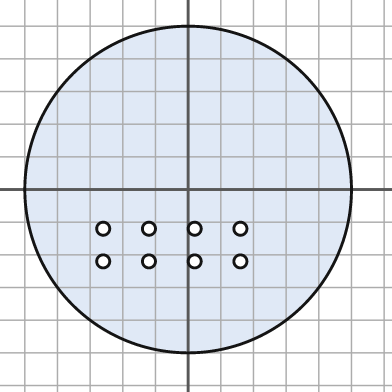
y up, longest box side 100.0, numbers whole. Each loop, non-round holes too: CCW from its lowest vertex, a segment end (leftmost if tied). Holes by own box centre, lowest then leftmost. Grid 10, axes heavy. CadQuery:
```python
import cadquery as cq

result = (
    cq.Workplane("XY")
    .moveTo(0.0, 0.0)
    .circle(50.0)
    .moveTo(-26.0, -22.0)
    .circle(2.0)
    .moveTo(-12.0, -22.0)
    .circle(2.0)
    .moveTo(2.0, -22.0)
    .circle(2.0)
    .moveTo(16.0, -22.0)
    .circle(2.0)
    .moveTo(-26.0, -12.0)
    .circle(2.0)
    .moveTo(-12.0, -12.0)
    .circle(2.0)
    .moveTo(2.0, -12.0)
    .circle(2.0)
    .moveTo(16.0, -12.0)
    .circle(2.0)
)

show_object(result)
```